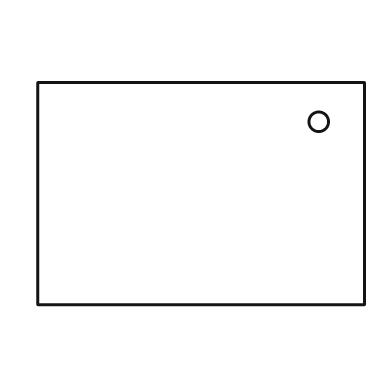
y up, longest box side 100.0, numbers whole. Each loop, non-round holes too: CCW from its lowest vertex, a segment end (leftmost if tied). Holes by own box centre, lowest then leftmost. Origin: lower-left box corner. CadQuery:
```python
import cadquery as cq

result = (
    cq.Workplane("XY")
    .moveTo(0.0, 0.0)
    .lineTo(100.0, 0.0)
    .lineTo(100.0, 68.0)
    .lineTo(0.0, 68.0)
    .close()
    .moveTo(86.0, 56.0)
    .circle(3.0)
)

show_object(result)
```